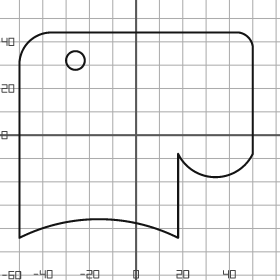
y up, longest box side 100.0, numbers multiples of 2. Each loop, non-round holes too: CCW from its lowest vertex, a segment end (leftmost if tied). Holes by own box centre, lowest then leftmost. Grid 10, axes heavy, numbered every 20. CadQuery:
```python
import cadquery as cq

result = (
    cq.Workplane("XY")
    .moveTo(-50.0, -44.0)
    .threePointArc((-16.0, -36.0), (18.0, -44.0))
    .lineTo(18.0, -8.0)
    .threePointArc((34.0, -18.0), (50.0, -8.0))
    .lineTo(50.0, 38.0)
    .threePointArc((48.0, 42.0), (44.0, 44.0))
    .lineTo(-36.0, 44.0)
    .threePointArc((-46.0, 40.0), (-50.0, 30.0))
    .close()
    .moveTo(-26.0, 32.0)
    .circle(4.0)
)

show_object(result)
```